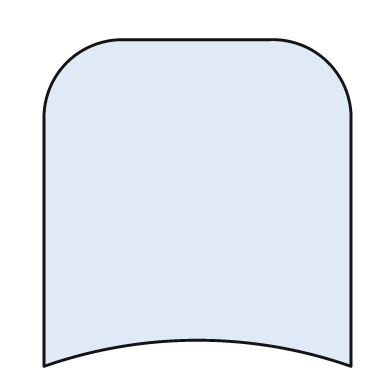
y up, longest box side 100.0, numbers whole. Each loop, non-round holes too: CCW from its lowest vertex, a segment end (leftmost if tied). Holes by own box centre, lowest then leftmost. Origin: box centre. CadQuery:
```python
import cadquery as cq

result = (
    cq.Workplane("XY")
    .moveTo(-47.0, -50.0)
    .threePointArc((0.0, -42.0), (47.0, -50.0))
    .lineTo(47.0, 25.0)
    .threePointArc((40.0, 43.0), (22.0, 50.0))
    .lineTo(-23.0, 50.0)
    .threePointArc((-40.0, 43.0), (-47.0, 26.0))
    .close()
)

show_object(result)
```